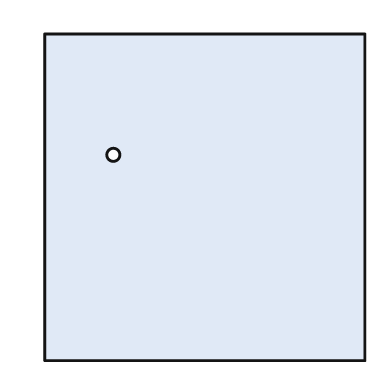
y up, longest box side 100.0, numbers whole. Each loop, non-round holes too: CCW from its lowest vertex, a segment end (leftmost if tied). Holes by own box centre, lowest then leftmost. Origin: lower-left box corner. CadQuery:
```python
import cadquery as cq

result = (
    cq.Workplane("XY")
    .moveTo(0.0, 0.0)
    .lineTo(98.0, 0.0)
    .lineTo(98.0, 100.0)
    .lineTo(0.0, 100.0)
    .close()
    .moveTo(21.0, 63.0)
    .circle(2.0)
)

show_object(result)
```